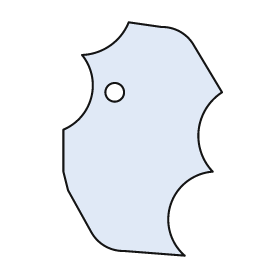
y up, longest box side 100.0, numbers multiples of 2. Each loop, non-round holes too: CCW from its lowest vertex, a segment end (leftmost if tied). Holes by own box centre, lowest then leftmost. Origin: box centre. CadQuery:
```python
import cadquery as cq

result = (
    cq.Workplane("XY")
    .moveTo(18.0, -50.0)
    .threePointArc((12.0, -28.0), (30.0, -14.0))
    .threePointArc((24.0, 4.0), (34.0, 20.0))
    .lineTo(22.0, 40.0)
    .threePointArc((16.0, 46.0), (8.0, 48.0))
    .lineTo(-6.0, 50.0)
    .threePointArc((-14.0, 40.0), (-26.0, 36.0))
    .threePointArc((-22.0, 18.0), (-34.0, 4.0))
    .lineTo(-34.0, -14.0)
    .lineTo(-32.0, -22.0)
    .lineTo(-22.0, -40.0)
    .threePointArc((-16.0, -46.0), (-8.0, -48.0))
    .close()
    .moveTo(-12.0, 20.0)
    .circle(4.0)
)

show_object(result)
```